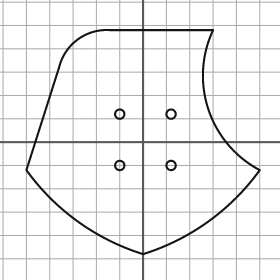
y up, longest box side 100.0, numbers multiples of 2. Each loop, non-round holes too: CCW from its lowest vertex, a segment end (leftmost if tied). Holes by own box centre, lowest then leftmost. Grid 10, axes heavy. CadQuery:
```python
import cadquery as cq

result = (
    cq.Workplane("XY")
    .moveTo(0.0, -48.0)
    .threePointArc((28.0, -34.0), (50.0, -12.0))
    .threePointArc((28.0, 14.0), (30.0, 48.0))
    .lineTo(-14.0, 48.0)
    .threePointArc((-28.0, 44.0), (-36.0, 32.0))
    .lineTo(-50.0, -12.0)
    .threePointArc((-28.0, -34.0), (0.0, -48.0))
    .close()
    .moveTo(-10.0, -10.0)
    .circle(2.0)
    .moveTo(12.0, -10.0)
    .circle(2.0)
    .moveTo(-10.0, 12.0)
    .circle(2.0)
    .moveTo(12.0, 12.0)
    .circle(2.0)
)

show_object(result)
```